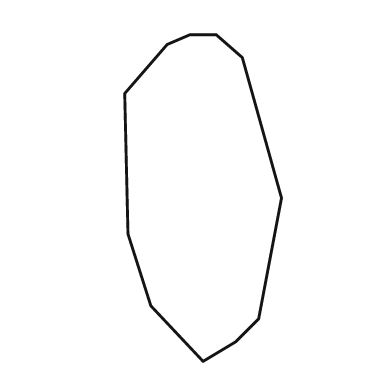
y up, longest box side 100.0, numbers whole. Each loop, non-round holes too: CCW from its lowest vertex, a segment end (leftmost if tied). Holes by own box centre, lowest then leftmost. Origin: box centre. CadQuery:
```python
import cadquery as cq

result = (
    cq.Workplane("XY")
    .moveTo(0.0, -50.0)
    .lineTo(10.0, -44.0)
    .lineTo(17.0, -37.0)
    .lineTo(24.0, 0.0)
    .lineTo(12.0, 43.0)
    .lineTo(4.0, 50.0)
    .lineTo(-4.0, 50.0)
    .lineTo(-11.0, 47.0)
    .lineTo(-24.0, 32.0)
    .lineTo(-23.0, -11.0)
    .lineTo(-16.0, -33.0)
    .close()
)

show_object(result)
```